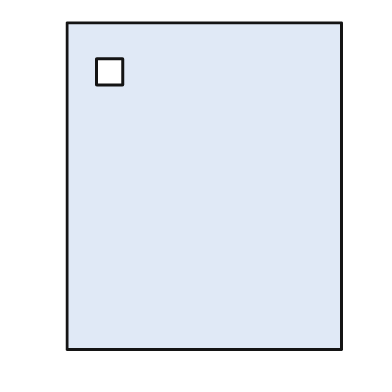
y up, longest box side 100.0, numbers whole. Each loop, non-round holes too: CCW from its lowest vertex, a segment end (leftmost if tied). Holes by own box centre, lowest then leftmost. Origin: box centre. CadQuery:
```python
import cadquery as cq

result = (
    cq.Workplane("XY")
    .moveTo(-42.0, -50.0)
    .lineTo(42.0, -50.0)
    .lineTo(42.0, 50.0)
    .lineTo(-42.0, 50.0)
    .close()
    .moveTo(-33.0, 31.0)
    .lineTo(-25.0, 31.0)
    .lineTo(-25.0, 39.0)
    .lineTo(-33.0, 39.0)
    .close()
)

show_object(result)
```